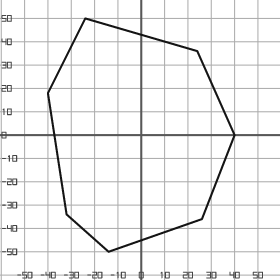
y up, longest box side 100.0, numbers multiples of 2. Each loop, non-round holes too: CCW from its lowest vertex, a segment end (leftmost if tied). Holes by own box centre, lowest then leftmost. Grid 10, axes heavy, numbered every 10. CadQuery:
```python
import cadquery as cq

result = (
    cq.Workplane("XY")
    .moveTo(-14.0, -50.0)
    .lineTo(26.0, -36.0)
    .lineTo(40.0, 0.0)
    .lineTo(24.0, 36.0)
    .lineTo(-24.0, 50.0)
    .lineTo(-40.0, 18.0)
    .lineTo(-32.0, -34.0)
    .close()
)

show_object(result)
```